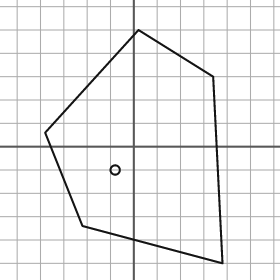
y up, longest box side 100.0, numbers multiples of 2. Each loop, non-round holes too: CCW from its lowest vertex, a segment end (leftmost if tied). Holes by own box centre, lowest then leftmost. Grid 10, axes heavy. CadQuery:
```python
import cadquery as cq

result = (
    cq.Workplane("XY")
    .moveTo(38.0, -50.0)
    .lineTo(34.0, 30.0)
    .lineTo(2.0, 50.0)
    .lineTo(-38.0, 6.0)
    .lineTo(-22.0, -34.0)
    .close()
    .moveTo(-8.0, -10.0)
    .circle(2.0)
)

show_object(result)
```